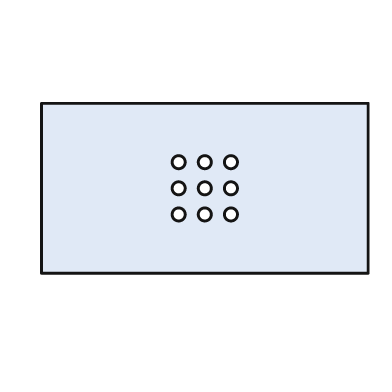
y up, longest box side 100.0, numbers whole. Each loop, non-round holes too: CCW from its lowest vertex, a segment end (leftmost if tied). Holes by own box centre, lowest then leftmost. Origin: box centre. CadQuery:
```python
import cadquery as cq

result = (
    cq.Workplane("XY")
    .moveTo(-50.0, -26.0)
    .lineTo(50.0, -26.0)
    .lineTo(50.0, 26.0)
    .lineTo(-50.0, 26.0)
    .close()
    .moveTo(-8.0, -8.0)
    .circle(2.0)
    .moveTo(0.0, -8.0)
    .circle(2.0)
    .moveTo(8.0, -8.0)
    .circle(2.0)
    .moveTo(-8.0, 0.0)
    .circle(2.0)
    .moveTo(0.0, 0.0)
    .circle(2.0)
    .moveTo(8.0, 0.0)
    .circle(2.0)
    .moveTo(-8.0, 8.0)
    .circle(2.0)
    .moveTo(0.0, 8.0)
    .circle(2.0)
    .moveTo(8.0, 8.0)
    .circle(2.0)
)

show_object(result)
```